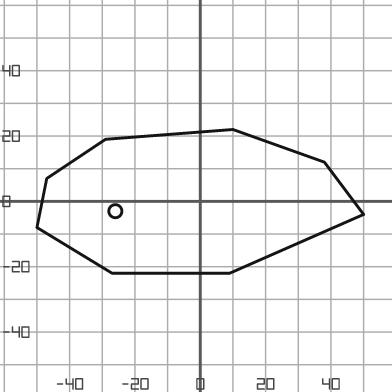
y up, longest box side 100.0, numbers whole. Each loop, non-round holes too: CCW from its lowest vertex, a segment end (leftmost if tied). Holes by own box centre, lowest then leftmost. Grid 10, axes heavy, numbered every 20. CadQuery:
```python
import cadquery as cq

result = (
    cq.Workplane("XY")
    .moveTo(-27.0, -22.0)
    .lineTo(9.0, -22.0)
    .lineTo(50.0, -4.0)
    .lineTo(38.0, 12.0)
    .lineTo(10.0, 22.0)
    .lineTo(-29.0, 19.0)
    .lineTo(-47.0, 7.0)
    .lineTo(-50.0, -8.0)
    .close()
    .moveTo(-26.0, -3.0)
    .circle(2.0)
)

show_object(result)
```